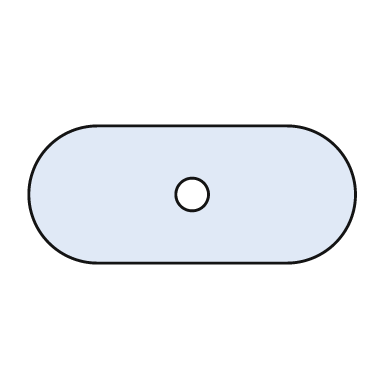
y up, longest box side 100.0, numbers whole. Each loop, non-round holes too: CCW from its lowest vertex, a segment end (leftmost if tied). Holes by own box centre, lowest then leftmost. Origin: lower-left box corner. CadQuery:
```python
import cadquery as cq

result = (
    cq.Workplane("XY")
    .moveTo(21.0, 0.0)
    .lineTo(79.0, 0.0)
    .threePointArc((100.0, 21.0), (79.0, 42.0))
    .lineTo(21.0, 42.0)
    .threePointArc((0.0, 21.0), (21.0, 0.0))
    .close()
    .moveTo(50.0, 21.0)
    .circle(5.0)
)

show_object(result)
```